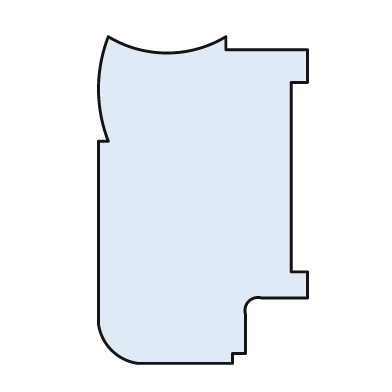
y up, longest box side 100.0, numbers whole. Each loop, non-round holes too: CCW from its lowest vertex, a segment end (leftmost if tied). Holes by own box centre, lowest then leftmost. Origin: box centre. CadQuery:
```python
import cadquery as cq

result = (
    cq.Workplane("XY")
    .moveTo(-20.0, -50.0)
    .lineTo(9.0, -50.0)
    .lineTo(9.0, -47.0)
    .lineTo(13.0, -47.0)
    .lineTo(13.0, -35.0)
    .threePointArc((14.0, -31.0), (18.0, -30.0))
    .lineTo(32.0, -30.0)
    .lineTo(32.0, -22.0)
    .lineTo(27.0, -22.0)
    .lineTo(27.0, 36.0)
    .lineTo(32.0, 36.0)
    .lineTo(32.0, 46.0)
    .lineTo(7.0, 46.0)
    .lineTo(7.0, 50.0)
    .threePointArc((-11.0, 45.0), (-29.0, 50.0))
    .threePointArc((-32.0, 34.0), (-29.0, 18.0))
    .lineTo(-32.0, 18.0)
    .lineTo(-32.0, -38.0)
    .threePointArc((-28.0, -46.0), (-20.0, -50.0))
    .close()
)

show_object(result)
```